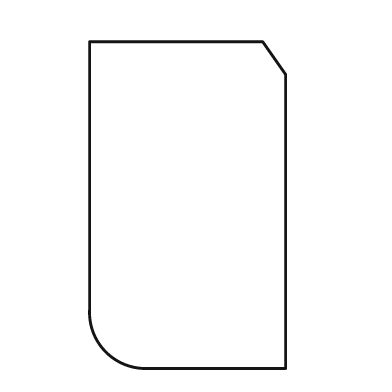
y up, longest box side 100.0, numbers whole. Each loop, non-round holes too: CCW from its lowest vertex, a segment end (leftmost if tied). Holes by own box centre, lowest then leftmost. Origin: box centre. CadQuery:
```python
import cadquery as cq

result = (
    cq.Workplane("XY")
    .moveTo(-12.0, -50.0)
    .lineTo(30.0, -50.0)
    .lineTo(30.0, 40.0)
    .lineTo(23.0, 50.0)
    .lineTo(-30.0, 50.0)
    .lineTo(-30.0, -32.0)
    .threePointArc((-25.0, -45.0), (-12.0, -50.0))
    .close()
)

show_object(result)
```